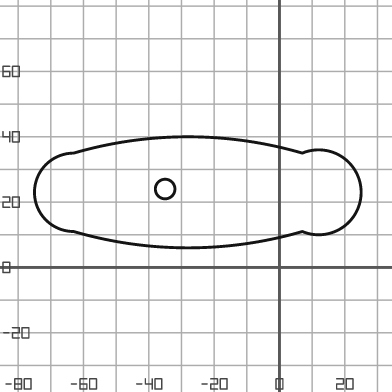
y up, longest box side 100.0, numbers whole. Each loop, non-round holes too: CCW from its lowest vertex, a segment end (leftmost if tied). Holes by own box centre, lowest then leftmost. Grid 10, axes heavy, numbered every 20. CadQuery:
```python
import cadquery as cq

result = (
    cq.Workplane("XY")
    .moveTo(-63.0, 11.0)
    .threePointArc((-28.0, 6.0), (7.0, 11.0))
    .threePointArc((25.0, 23.0), (7.0, 35.0))
    .threePointArc((-28.0, 40.0), (-63.0, 35.0))
    .threePointArc((-75.0, 23.0), (-63.0, 11.0))
    .close()
    .moveTo(-35.0, 24.0)
    .circle(3.0)
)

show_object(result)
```